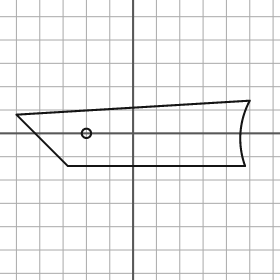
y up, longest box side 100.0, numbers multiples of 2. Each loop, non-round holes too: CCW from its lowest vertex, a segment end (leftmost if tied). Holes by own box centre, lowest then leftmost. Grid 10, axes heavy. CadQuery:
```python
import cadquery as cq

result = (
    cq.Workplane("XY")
    .moveTo(-28.0, -14.0)
    .lineTo(48.0, -14.0)
    .threePointArc((46.0, 0.0), (50.0, 14.0))
    .lineTo(-50.0, 8.0)
    .close()
    .moveTo(-20.0, 0.0)
    .circle(2.0)
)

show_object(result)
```